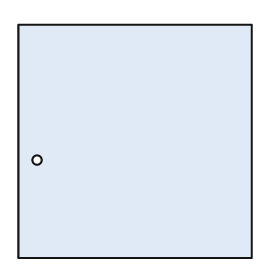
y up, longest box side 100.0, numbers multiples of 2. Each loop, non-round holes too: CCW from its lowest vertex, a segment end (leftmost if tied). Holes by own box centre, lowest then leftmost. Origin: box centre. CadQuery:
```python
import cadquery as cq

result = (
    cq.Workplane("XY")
    .moveTo(-50.0, -50.0)
    .lineTo(50.0, -50.0)
    .lineTo(50.0, 50.0)
    .lineTo(-50.0, 50.0)
    .close()
    .moveTo(-42.0, -8.0)
    .circle(2.0)
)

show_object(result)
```